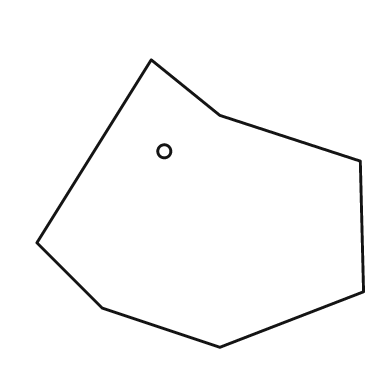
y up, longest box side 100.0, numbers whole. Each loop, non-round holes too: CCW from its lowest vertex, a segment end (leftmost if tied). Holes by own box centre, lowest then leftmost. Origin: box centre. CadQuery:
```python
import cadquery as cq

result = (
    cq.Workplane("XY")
    .moveTo(6.0, -44.0)
    .lineTo(50.0, -27.0)
    .lineTo(49.0, 13.0)
    .lineTo(6.0, 27.0)
    .lineTo(-15.0, 44.0)
    .lineTo(-50.0, -12.0)
    .lineTo(-30.0, -32.0)
    .close()
    .moveTo(-11.0, 16.0)
    .circle(2.0)
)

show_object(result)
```